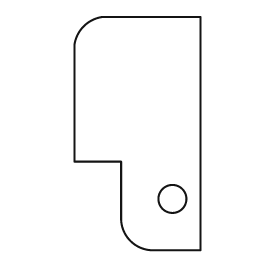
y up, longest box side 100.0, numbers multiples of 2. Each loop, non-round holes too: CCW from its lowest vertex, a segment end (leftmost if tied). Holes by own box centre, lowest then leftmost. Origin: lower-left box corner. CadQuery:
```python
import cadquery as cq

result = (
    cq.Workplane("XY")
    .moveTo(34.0, 0.0)
    .lineTo(54.0, 0.0)
    .lineTo(54.0, 100.0)
    .lineTo(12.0, 100.0)
    .threePointArc((4.0, 96.0), (0.0, 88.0))
    .lineTo(0.0, 38.0)
    .lineTo(20.0, 38.0)
    .lineTo(20.0, 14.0)
    .threePointArc((24.0, 4.0), (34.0, 0.0))
    .close()
    .moveTo(42.0, 22.0)
    .circle(6.0)
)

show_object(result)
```